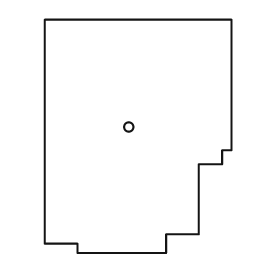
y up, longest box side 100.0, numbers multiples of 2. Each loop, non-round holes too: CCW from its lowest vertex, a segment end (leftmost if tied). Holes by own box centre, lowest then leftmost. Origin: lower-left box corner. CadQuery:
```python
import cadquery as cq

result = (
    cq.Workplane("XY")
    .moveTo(14.0, 0.0)
    .lineTo(52.0, 0.0)
    .lineTo(52.0, 8.0)
    .lineTo(66.0, 8.0)
    .lineTo(66.0, 38.0)
    .lineTo(76.0, 38.0)
    .lineTo(76.0, 44.0)
    .lineTo(80.0, 44.0)
    .lineTo(80.0, 100.0)
    .lineTo(0.0, 100.0)
    .lineTo(0.0, 4.0)
    .lineTo(14.0, 4.0)
    .close()
    .moveTo(36.0, 54.0)
    .circle(2.0)
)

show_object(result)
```